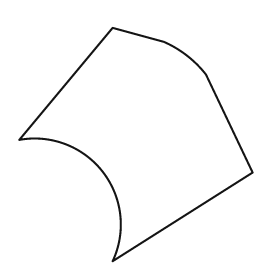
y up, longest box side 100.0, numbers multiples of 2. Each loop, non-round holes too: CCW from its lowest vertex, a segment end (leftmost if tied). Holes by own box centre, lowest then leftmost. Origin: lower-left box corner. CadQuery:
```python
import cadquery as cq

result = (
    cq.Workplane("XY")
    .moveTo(40.0, 0.0)
    .lineTo(100.0, 38.0)
    .lineTo(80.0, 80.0)
    .threePointArc((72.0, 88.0), (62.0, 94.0))
    .lineTo(40.0, 100.0)
    .lineTo(0.0, 52.0)
    .threePointArc((36.0, 38.0), (40.0, 0.0))
    .close()
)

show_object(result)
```